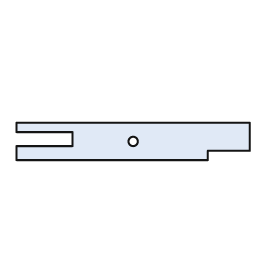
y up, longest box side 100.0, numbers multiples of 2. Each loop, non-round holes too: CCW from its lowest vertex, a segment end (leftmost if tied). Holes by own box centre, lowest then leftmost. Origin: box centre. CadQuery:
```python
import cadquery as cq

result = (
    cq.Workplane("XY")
    .moveTo(-50.0, -8.0)
    .lineTo(32.0, -8.0)
    .lineTo(32.0, -4.0)
    .lineTo(50.0, -4.0)
    .lineTo(50.0, 8.0)
    .lineTo(-50.0, 8.0)
    .lineTo(-50.0, 4.0)
    .lineTo(-26.0, 4.0)
    .lineTo(-26.0, -2.0)
    .lineTo(-50.0, -2.0)
    .close()
    .moveTo(0.0, 0.0)
    .circle(2.0)
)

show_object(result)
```